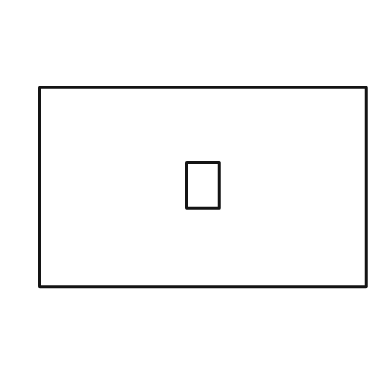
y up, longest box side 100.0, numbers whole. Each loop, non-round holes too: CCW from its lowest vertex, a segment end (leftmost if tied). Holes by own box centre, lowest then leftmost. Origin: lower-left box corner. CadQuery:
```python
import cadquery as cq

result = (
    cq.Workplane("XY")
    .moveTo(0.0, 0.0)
    .lineTo(100.0, 0.0)
    .lineTo(100.0, 61.0)
    .lineTo(0.0, 61.0)
    .close()
    .moveTo(45.0, 24.0)
    .lineTo(55.0, 24.0)
    .lineTo(55.0, 38.0)
    .lineTo(45.0, 38.0)
    .close()
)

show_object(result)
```